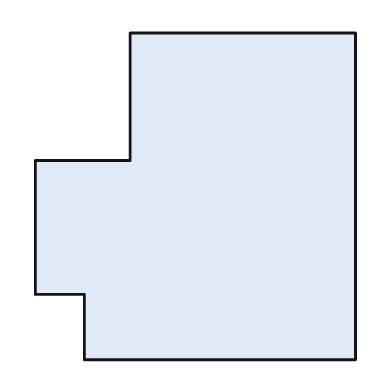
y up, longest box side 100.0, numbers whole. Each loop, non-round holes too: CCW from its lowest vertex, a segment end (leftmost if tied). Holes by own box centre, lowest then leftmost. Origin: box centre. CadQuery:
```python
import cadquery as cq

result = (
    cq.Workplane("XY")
    .moveTo(-34.0, -50.0)
    .lineTo(49.0, -50.0)
    .lineTo(49.0, 50.0)
    .lineTo(-20.0, 50.0)
    .lineTo(-20.0, 11.0)
    .lineTo(-49.0, 11.0)
    .lineTo(-49.0, -30.0)
    .lineTo(-34.0, -30.0)
    .close()
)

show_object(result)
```